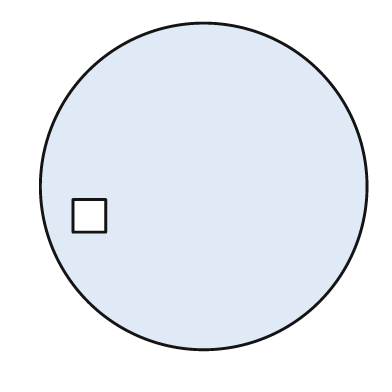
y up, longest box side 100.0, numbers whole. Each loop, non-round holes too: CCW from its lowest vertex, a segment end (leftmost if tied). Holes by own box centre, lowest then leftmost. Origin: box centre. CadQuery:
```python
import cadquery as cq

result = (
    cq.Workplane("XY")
    .moveTo(0.0, 0.0)
    .circle(50.0)
    .moveTo(-40.0, -14.0)
    .lineTo(-30.0, -14.0)
    .lineTo(-30.0, -4.0)
    .lineTo(-40.0, -4.0)
    .close()
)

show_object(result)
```